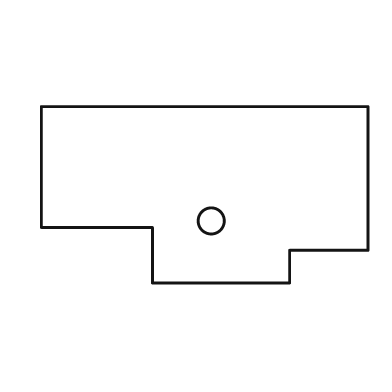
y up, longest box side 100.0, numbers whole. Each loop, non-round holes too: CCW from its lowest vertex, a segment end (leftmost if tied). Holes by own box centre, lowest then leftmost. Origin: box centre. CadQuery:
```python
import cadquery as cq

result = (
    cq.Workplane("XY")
    .moveTo(-16.0, -27.0)
    .lineTo(26.0, -27.0)
    .lineTo(26.0, -17.0)
    .lineTo(50.0, -17.0)
    .lineTo(50.0, 27.0)
    .lineTo(-50.0, 27.0)
    .lineTo(-50.0, -10.0)
    .lineTo(-16.0, -10.0)
    .close()
    .moveTo(2.0, -8.0)
    .circle(4.0)
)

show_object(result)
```